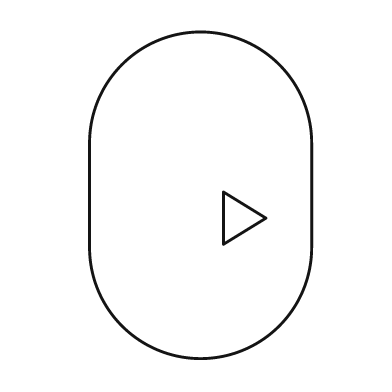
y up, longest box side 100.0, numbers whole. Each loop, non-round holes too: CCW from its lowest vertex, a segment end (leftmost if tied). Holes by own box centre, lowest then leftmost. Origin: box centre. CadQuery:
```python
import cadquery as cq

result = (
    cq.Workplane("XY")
    .moveTo(-34.0, -16.0)
    .threePointArc((0.0, -50.0), (34.0, -16.0))
    .lineTo(34.0, 16.0)
    .threePointArc((0.0, 50.0), (-34.0, 16.0))
    .close()
    .moveTo(7.0, -15.0)
    .lineTo(20.0, -7.0)
    .lineTo(7.0, 1.0)
    .close()
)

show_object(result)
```